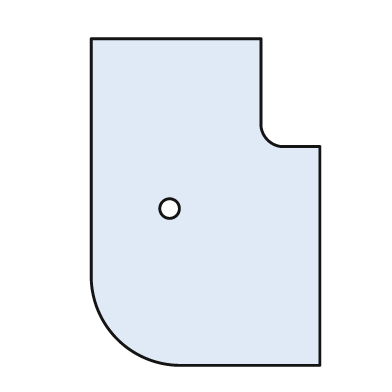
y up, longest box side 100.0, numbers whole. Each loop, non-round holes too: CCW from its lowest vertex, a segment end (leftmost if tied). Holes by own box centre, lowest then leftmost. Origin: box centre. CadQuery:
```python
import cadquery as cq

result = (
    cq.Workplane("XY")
    .moveTo(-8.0, -50.0)
    .lineTo(35.0, -50.0)
    .lineTo(35.0, 17.0)
    .lineTo(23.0, 17.0)
    .threePointArc((19.0, 19.0), (17.0, 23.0))
    .lineTo(17.0, 50.0)
    .lineTo(-35.0, 50.0)
    .lineTo(-35.0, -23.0)
    .threePointArc((-27.0, -42.0), (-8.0, -50.0))
    .close()
    .moveTo(-11.0, -2.0)
    .circle(3.0)
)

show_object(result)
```